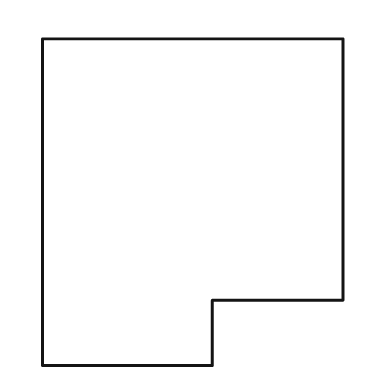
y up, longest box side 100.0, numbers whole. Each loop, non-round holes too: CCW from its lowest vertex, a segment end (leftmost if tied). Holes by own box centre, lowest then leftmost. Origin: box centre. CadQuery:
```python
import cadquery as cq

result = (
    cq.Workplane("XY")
    .moveTo(-46.0, -50.0)
    .lineTo(6.0, -50.0)
    .lineTo(6.0, -30.0)
    .lineTo(46.0, -30.0)
    .lineTo(46.0, 50.0)
    .lineTo(-46.0, 50.0)
    .close()
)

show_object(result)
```